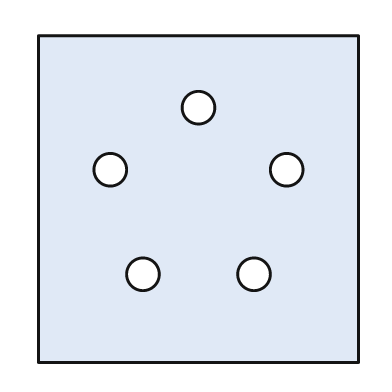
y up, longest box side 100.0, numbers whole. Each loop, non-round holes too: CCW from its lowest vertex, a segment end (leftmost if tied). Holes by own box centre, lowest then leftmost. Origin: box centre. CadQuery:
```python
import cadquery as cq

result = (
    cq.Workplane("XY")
    .moveTo(-49.0, -50.0)
    .lineTo(49.0, -50.0)
    .lineTo(49.0, 50.0)
    .lineTo(-49.0, 50.0)
    .close()
    .moveTo(-17.0, -23.0)
    .circle(5.0)
    .moveTo(17.0, -23.0)
    .circle(5.0)
    .moveTo(-27.0, 9.0)
    .circle(5.0)
    .moveTo(27.0, 9.0)
    .circle(5.0)
    .moveTo(0.0, 28.0)
    .circle(5.0)
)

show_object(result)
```